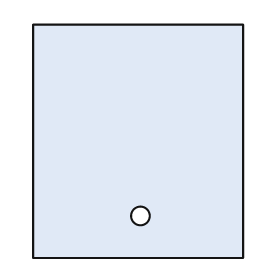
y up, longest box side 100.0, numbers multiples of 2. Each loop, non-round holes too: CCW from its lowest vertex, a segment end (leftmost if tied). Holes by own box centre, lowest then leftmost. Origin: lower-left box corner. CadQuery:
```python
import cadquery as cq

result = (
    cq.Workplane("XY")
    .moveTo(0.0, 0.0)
    .lineTo(90.0, 0.0)
    .lineTo(90.0, 100.0)
    .lineTo(0.0, 100.0)
    .close()
    .moveTo(46.0, 18.0)
    .circle(4.0)
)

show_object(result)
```